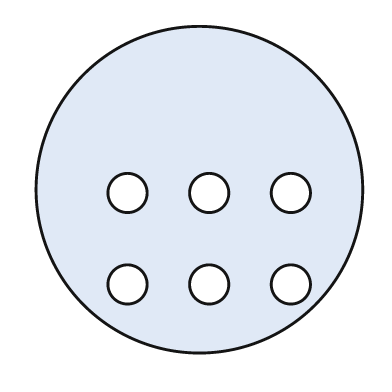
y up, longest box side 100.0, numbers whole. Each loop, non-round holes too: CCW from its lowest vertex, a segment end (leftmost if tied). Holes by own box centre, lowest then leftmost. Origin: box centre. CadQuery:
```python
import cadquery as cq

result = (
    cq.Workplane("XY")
    .moveTo(0.0, 0.0)
    .circle(50.0)
    .moveTo(-22.0, -29.0)
    .circle(6.0)
    .moveTo(3.0, -29.0)
    .circle(6.0)
    .moveTo(28.0, -29.0)
    .circle(6.0)
    .moveTo(-22.0, -1.0)
    .circle(6.0)
    .moveTo(3.0, -1.0)
    .circle(6.0)
    .moveTo(28.0, -1.0)
    .circle(6.0)
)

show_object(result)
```